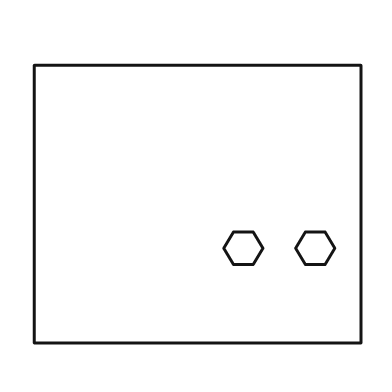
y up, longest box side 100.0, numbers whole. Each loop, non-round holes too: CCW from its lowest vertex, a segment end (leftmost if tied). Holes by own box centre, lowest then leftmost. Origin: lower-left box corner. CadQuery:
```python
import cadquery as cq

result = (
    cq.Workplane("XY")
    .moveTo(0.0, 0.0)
    .lineTo(100.0, 0.0)
    .lineTo(100.0, 85.0)
    .lineTo(0.0, 85.0)
    .close()
    .moveTo(61.0, 24.0)
    .lineTo(67.0, 24.0)
    .lineTo(70.0, 29.0)
    .lineTo(67.0, 34.0)
    .lineTo(61.0, 34.0)
    .lineTo(58.0, 29.0)
    .close()
    .moveTo(83.0, 24.0)
    .lineTo(89.0, 24.0)
    .lineTo(92.0, 29.0)
    .lineTo(89.0, 34.0)
    .lineTo(83.0, 34.0)
    .lineTo(80.0, 29.0)
    .close()
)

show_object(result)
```